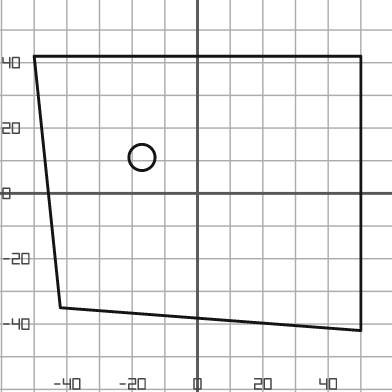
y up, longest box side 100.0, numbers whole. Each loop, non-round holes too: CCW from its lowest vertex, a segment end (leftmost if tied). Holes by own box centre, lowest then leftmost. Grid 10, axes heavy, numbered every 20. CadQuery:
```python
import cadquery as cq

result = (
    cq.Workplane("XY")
    .moveTo(50.0, -42.0)
    .lineTo(50.0, 42.0)
    .lineTo(-50.0, 42.0)
    .lineTo(-42.0, -35.0)
    .close()
    .moveTo(-17.0, 11.0)
    .circle(4.0)
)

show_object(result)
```